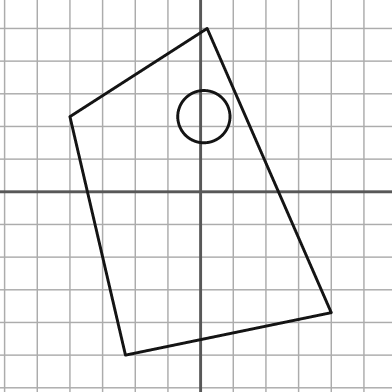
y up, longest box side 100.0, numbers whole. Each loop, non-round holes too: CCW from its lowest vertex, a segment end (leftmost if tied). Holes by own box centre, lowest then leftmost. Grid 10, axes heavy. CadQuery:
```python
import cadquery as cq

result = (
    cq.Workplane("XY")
    .moveTo(-23.0, -50.0)
    .lineTo(40.0, -37.0)
    .lineTo(2.0, 50.0)
    .lineTo(-40.0, 23.0)
    .close()
    .moveTo(1.0, 23.0)
    .circle(8.0)
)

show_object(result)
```